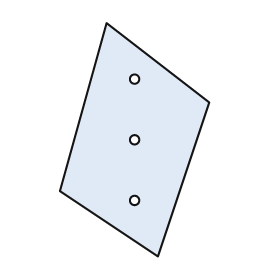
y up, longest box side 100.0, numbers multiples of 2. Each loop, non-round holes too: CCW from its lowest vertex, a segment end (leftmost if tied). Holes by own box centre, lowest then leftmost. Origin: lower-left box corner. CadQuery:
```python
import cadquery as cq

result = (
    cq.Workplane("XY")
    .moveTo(42.0, 0.0)
    .lineTo(64.0, 66.0)
    .lineTo(20.0, 100.0)
    .lineTo(0.0, 28.0)
    .close()
    .moveTo(32.0, 24.0)
    .circle(2.0)
    .moveTo(32.0, 50.0)
    .circle(2.0)
    .moveTo(32.0, 76.0)
    .circle(2.0)
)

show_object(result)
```